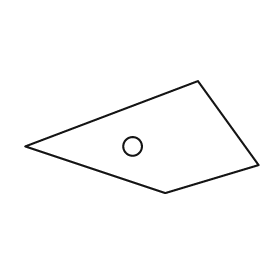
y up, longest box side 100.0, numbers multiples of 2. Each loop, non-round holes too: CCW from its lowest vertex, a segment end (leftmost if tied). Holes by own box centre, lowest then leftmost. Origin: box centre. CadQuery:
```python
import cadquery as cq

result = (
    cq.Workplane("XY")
    .moveTo(10.0, -24.0)
    .lineTo(50.0, -12.0)
    .lineTo(24.0, 24.0)
    .lineTo(-50.0, -4.0)
    .close()
    .moveTo(-4.0, -4.0)
    .circle(4.0)
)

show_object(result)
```